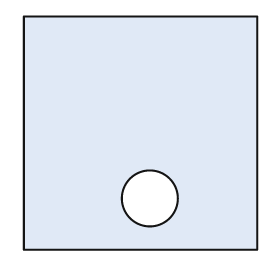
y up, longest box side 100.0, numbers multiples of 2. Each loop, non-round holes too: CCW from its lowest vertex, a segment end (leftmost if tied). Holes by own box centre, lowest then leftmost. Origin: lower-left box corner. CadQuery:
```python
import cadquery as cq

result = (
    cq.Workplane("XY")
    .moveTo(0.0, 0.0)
    .lineTo(100.0, 0.0)
    .lineTo(100.0, 100.0)
    .lineTo(0.0, 100.0)
    .close()
    .moveTo(54.0, 22.0)
    .circle(12.0)
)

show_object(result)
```